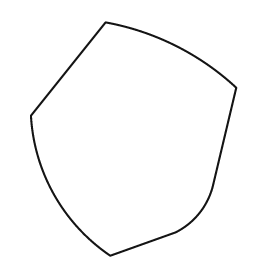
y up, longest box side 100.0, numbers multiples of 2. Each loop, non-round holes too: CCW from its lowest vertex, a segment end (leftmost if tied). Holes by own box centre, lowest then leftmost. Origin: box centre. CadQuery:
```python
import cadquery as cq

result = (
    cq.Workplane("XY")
    .moveTo(-10.0, -50.0)
    .lineTo(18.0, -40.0)
    .threePointArc((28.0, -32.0), (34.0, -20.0))
    .lineTo(44.0, 22.0)
    .threePointArc((18.0, 40.0), (-12.0, 50.0))
    .lineTo(-44.0, 10.0)
    .threePointArc((-34.0, -24.0), (-10.0, -50.0))
    .close()
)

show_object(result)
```